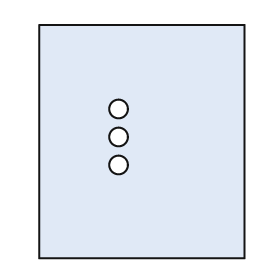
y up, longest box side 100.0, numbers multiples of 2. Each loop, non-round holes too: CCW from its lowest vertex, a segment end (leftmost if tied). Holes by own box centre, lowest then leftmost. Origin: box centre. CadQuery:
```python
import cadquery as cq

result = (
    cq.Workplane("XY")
    .moveTo(-44.0, -50.0)
    .lineTo(44.0, -50.0)
    .lineTo(44.0, 50.0)
    .lineTo(-44.0, 50.0)
    .close()
    .moveTo(-10.0, -10.0)
    .circle(4.0)
    .moveTo(-10.0, 2.0)
    .circle(4.0)
    .moveTo(-10.0, 14.0)
    .circle(4.0)
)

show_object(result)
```